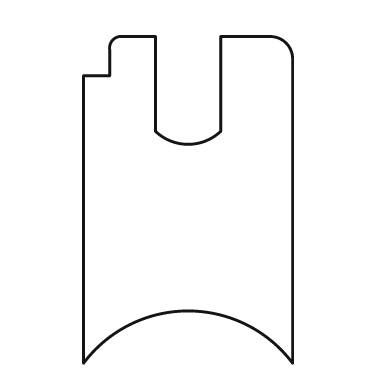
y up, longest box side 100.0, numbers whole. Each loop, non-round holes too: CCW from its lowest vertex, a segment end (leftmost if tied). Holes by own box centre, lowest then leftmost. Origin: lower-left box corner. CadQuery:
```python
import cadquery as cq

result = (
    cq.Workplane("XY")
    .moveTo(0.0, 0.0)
    .threePointArc((32.0, 16.0), (64.0, 0.0))
    .lineTo(64.0, 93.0)
    .threePointArc((62.0, 98.0), (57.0, 100.0))
    .lineTo(42.0, 100.0)
    .lineTo(42.0, 71.0)
    .threePointArc((32.0, 67.0), (22.0, 71.0))
    .lineTo(22.0, 100.0)
    .lineTo(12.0, 100.0)
    .threePointArc((9.0, 99.0), (8.0, 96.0))
    .lineTo(8.0, 88.0)
    .lineTo(0.0, 88.0)
    .close()
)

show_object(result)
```